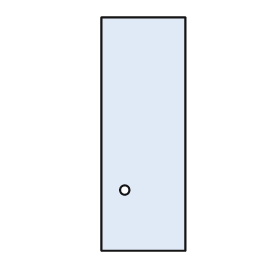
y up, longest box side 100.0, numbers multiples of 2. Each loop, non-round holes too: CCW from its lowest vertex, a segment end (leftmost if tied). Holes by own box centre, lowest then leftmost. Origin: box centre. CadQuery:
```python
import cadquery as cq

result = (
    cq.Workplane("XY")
    .moveTo(-18.0, -50.0)
    .lineTo(18.0, -50.0)
    .lineTo(18.0, 50.0)
    .lineTo(-18.0, 50.0)
    .close()
    .moveTo(-8.0, -24.0)
    .circle(2.0)
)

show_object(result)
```